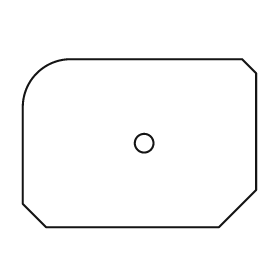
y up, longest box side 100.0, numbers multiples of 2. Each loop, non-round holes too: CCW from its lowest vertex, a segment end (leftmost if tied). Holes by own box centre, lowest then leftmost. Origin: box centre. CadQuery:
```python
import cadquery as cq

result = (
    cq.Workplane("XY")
    .moveTo(-40.0, -36.0)
    .lineTo(34.0, -36.0)
    .lineTo(50.0, -20.0)
    .lineTo(50.0, 30.0)
    .lineTo(44.0, 36.0)
    .lineTo(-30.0, 36.0)
    .threePointArc((-44.0, 30.0), (-50.0, 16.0))
    .lineTo(-50.0, -26.0)
    .close()
    .moveTo(2.0, 0.0)
    .circle(4.0)
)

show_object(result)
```